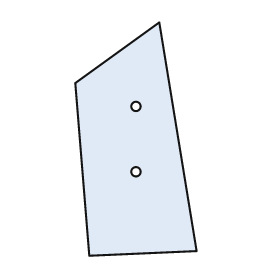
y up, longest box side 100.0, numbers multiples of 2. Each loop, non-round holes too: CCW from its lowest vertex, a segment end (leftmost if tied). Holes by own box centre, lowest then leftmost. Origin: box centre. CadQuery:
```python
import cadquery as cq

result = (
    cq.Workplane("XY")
    .moveTo(-20.0, -50.0)
    .lineTo(26.0, -48.0)
    .lineTo(10.0, 50.0)
    .lineTo(-26.0, 24.0)
    .close()
    .moveTo(0.0, -14.0)
    .circle(2.0)
    .moveTo(0.0, 14.0)
    .circle(2.0)
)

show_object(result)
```